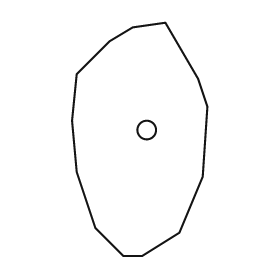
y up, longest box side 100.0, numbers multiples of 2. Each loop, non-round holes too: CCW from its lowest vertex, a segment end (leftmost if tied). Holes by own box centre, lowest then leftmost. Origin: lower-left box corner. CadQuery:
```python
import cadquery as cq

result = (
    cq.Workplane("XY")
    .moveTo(22.0, 0.0)
    .lineTo(30.0, 0.0)
    .lineTo(46.0, 10.0)
    .lineTo(56.0, 34.0)
    .lineTo(58.0, 64.0)
    .lineTo(54.0, 76.0)
    .lineTo(40.0, 100.0)
    .lineTo(26.0, 98.0)
    .lineTo(16.0, 92.0)
    .lineTo(2.0, 78.0)
    .lineTo(0.0, 58.0)
    .lineTo(2.0, 36.0)
    .lineTo(10.0, 12.0)
    .close()
    .moveTo(32.0, 54.0)
    .circle(4.0)
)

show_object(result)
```